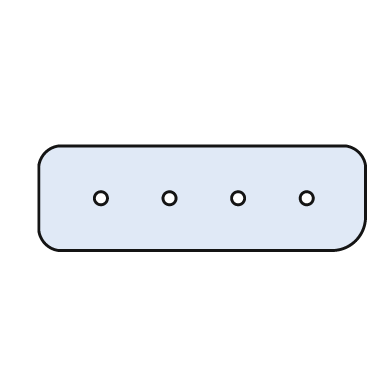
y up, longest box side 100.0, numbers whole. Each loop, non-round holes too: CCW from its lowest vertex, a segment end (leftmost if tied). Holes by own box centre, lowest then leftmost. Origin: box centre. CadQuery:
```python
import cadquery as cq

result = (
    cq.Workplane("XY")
    .moveTo(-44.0, -16.0)
    .lineTo(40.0, -16.0)
    .threePointArc((47.0, -13.0), (50.0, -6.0))
    .lineTo(50.0, 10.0)
    .threePointArc((48.0, 14.0), (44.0, 16.0))
    .lineTo(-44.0, 16.0)
    .threePointArc((-48.0, 14.0), (-50.0, 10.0))
    .lineTo(-50.0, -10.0)
    .threePointArc((-48.0, -14.0), (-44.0, -16.0))
    .close()
    .moveTo(-31.0, 0.0)
    .circle(2.0)
    .moveTo(-10.0, 0.0)
    .circle(2.0)
    .moveTo(11.0, 0.0)
    .circle(2.0)
    .moveTo(32.0, 0.0)
    .circle(2.0)
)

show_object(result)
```